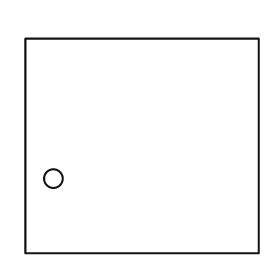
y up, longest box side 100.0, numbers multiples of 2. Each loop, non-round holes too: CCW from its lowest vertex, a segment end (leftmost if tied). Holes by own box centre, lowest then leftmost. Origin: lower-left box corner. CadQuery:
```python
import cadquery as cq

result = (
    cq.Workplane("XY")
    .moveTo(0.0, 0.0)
    .lineTo(100.0, 0.0)
    .lineTo(100.0, 92.0)
    .lineTo(0.0, 92.0)
    .close()
    .moveTo(12.0, 32.0)
    .circle(4.0)
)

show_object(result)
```